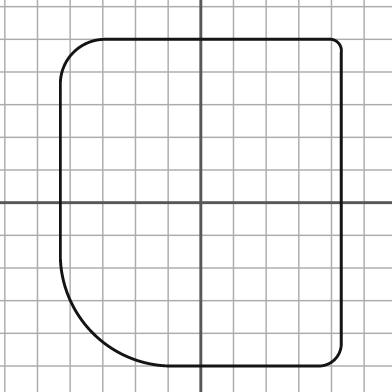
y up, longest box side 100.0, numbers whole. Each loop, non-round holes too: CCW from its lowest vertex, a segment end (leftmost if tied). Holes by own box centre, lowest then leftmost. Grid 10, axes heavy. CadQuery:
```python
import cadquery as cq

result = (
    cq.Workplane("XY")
    .moveTo(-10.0, -50.0)
    .lineTo(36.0, -50.0)
    .threePointArc((41.0, -48.0), (43.0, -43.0))
    .lineTo(43.0, 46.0)
    .threePointArc((42.0, 49.0), (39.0, 50.0))
    .lineTo(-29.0, 50.0)
    .threePointArc((-39.0, 46.0), (-43.0, 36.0))
    .lineTo(-43.0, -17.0)
    .threePointArc((-33.0, -40.0), (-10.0, -50.0))
    .close()
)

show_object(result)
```